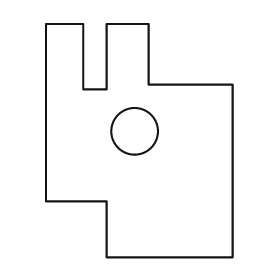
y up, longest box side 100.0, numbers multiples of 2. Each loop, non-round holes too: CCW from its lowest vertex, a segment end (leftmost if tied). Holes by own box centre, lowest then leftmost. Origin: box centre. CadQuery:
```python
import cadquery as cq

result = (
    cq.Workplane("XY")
    .moveTo(-14.0, -50.0)
    .lineTo(40.0, -50.0)
    .lineTo(40.0, 24.0)
    .lineTo(4.0, 24.0)
    .lineTo(4.0, 50.0)
    .lineTo(-14.0, 50.0)
    .lineTo(-14.0, 22.0)
    .lineTo(-24.0, 22.0)
    .lineTo(-24.0, 50.0)
    .lineTo(-40.0, 50.0)
    .lineTo(-40.0, -26.0)
    .lineTo(-14.0, -26.0)
    .close()
    .moveTo(-2.0, 4.0)
    .circle(10.0)
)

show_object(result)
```